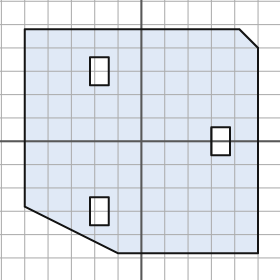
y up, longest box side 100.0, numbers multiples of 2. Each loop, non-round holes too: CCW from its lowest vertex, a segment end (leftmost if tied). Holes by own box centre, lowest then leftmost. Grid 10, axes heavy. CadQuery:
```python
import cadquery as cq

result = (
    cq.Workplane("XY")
    .moveTo(-10.0, -48.0)
    .lineTo(50.0, -48.0)
    .lineTo(50.0, 40.0)
    .lineTo(42.0, 48.0)
    .lineTo(-50.0, 48.0)
    .lineTo(-50.0, -28.0)
    .close()
    .moveTo(-22.0, -36.0)
    .lineTo(-14.0, -36.0)
    .lineTo(-14.0, -24.0)
    .lineTo(-22.0, -24.0)
    .close()
    .moveTo(30.0, -6.0)
    .lineTo(38.0, -6.0)
    .lineTo(38.0, 6.0)
    .lineTo(30.0, 6.0)
    .close()
    .moveTo(-22.0, 24.0)
    .lineTo(-14.0, 24.0)
    .lineTo(-14.0, 36.0)
    .lineTo(-22.0, 36.0)
    .close()
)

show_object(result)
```